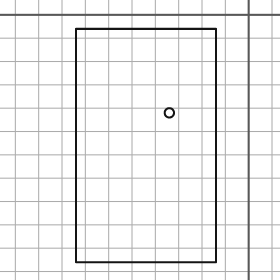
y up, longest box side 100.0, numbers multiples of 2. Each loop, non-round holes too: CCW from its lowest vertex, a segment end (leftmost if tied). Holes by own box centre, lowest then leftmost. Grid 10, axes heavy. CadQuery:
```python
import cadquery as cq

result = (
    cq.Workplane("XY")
    .moveTo(-74.0, -106.0)
    .lineTo(-14.0, -106.0)
    .lineTo(-14.0, -6.0)
    .lineTo(-74.0, -6.0)
    .close()
    .moveTo(-34.0, -42.0)
    .circle(2.0)
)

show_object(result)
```